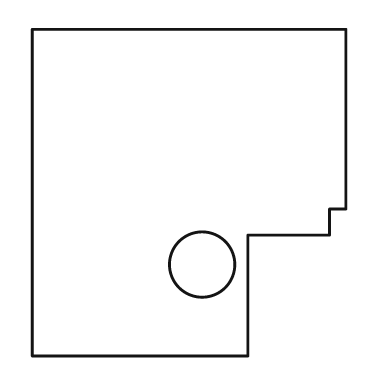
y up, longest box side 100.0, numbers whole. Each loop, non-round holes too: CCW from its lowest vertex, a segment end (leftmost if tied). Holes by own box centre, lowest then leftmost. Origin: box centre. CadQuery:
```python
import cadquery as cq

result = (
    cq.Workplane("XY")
    .moveTo(-48.0, -50.0)
    .lineTo(18.0, -50.0)
    .lineTo(18.0, -13.0)
    .lineTo(43.0, -13.0)
    .lineTo(43.0, -5.0)
    .lineTo(48.0, -5.0)
    .lineTo(48.0, 50.0)
    .lineTo(-48.0, 50.0)
    .close()
    .moveTo(4.0, -22.0)
    .circle(10.0)
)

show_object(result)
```